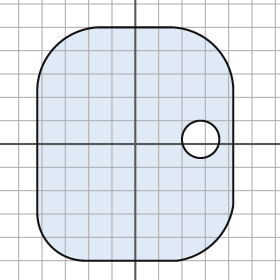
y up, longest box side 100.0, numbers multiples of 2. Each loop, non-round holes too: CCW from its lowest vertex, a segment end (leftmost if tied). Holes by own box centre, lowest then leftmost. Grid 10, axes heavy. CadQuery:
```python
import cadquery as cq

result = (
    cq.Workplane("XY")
    .moveTo(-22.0, -50.0)
    .lineTo(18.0, -50.0)
    .threePointArc((34.0, -42.0), (42.0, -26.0))
    .lineTo(42.0, 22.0)
    .threePointArc((34.0, 42.0), (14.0, 50.0))
    .lineTo(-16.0, 50.0)
    .threePointArc((-34.0, 42.0), (-42.0, 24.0))
    .lineTo(-42.0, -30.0)
    .threePointArc((-36.0, -44.0), (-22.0, -50.0))
    .close()
    .moveTo(28.0, 2.0)
    .circle(8.0)
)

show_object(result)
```